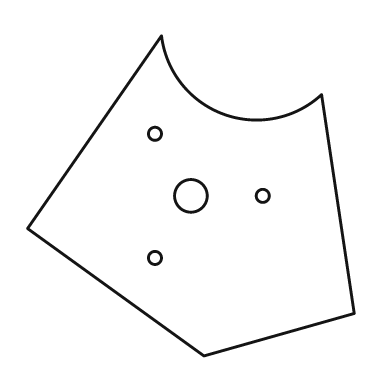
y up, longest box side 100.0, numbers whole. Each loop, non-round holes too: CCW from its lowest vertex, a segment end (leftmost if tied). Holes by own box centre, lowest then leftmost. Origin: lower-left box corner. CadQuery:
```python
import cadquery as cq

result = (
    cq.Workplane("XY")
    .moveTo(54.0, 0.0)
    .lineTo(100.0, 13.0)
    .lineTo(90.0, 80.0)
    .threePointArc((60.0, 74.0), (41.0, 98.0))
    .lineTo(0.0, 39.0)
    .close()
    .moveTo(39.0, 30.0)
    .circle(2.0)
    .moveTo(50.0, 49.0)
    .circle(5.0)
    .moveTo(72.0, 49.0)
    .circle(2.0)
    .moveTo(39.0, 68.0)
    .circle(2.0)
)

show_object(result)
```